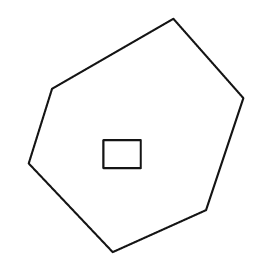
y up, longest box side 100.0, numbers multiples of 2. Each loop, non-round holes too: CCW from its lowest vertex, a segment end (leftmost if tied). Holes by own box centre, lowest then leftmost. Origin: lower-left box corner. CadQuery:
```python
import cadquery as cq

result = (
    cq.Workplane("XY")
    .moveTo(36.0, 0.0)
    .lineTo(76.0, 18.0)
    .lineTo(92.0, 66.0)
    .lineTo(62.0, 100.0)
    .lineTo(10.0, 70.0)
    .lineTo(0.0, 38.0)
    .close()
    .moveTo(32.0, 36.0)
    .lineTo(48.0, 36.0)
    .lineTo(48.0, 48.0)
    .lineTo(32.0, 48.0)
    .close()
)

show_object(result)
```